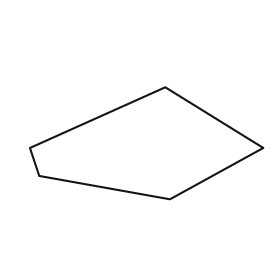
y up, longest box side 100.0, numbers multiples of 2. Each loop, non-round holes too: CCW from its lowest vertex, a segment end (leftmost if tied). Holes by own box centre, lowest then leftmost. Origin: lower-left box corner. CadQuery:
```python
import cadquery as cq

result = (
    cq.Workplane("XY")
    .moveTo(60.0, 0.0)
    .lineTo(100.0, 22.0)
    .lineTo(58.0, 48.0)
    .lineTo(0.0, 22.0)
    .lineTo(4.0, 10.0)
    .close()
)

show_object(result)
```